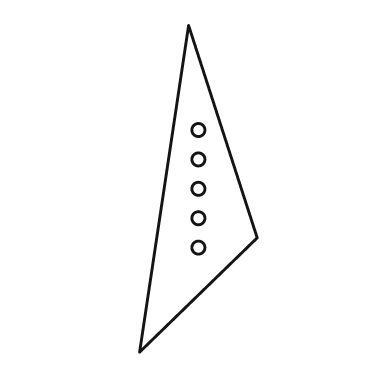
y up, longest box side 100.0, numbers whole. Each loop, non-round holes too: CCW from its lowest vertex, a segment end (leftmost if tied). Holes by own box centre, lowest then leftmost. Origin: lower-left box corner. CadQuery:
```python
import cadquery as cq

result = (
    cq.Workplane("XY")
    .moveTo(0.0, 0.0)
    .lineTo(36.0, 35.0)
    .lineTo(15.0, 100.0)
    .close()
    .moveTo(18.0, 32.0)
    .circle(2.0)
    .moveTo(18.0, 41.0)
    .circle(2.0)
    .moveTo(18.0, 50.0)
    .circle(2.0)
    .moveTo(18.0, 59.0)
    .circle(2.0)
    .moveTo(18.0, 68.0)
    .circle(2.0)
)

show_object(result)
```